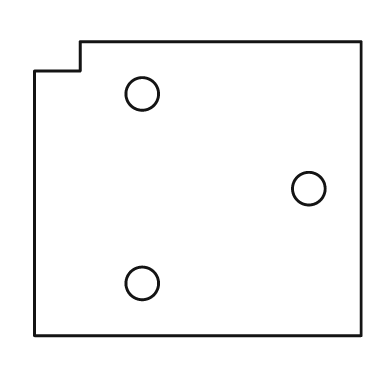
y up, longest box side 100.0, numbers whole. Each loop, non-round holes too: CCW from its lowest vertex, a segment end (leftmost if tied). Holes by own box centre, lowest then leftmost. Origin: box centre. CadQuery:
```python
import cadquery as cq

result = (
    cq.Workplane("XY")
    .moveTo(-50.0, -45.0)
    .lineTo(50.0, -45.0)
    .lineTo(50.0, 45.0)
    .lineTo(-36.0, 45.0)
    .lineTo(-36.0, 36.0)
    .lineTo(-50.0, 36.0)
    .close()
    .moveTo(-17.0, -29.0)
    .circle(5.0)
    .moveTo(34.0, 0.0)
    .circle(5.0)
    .moveTo(-17.0, 29.0)
    .circle(5.0)
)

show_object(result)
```